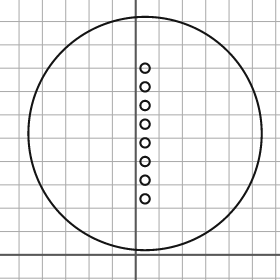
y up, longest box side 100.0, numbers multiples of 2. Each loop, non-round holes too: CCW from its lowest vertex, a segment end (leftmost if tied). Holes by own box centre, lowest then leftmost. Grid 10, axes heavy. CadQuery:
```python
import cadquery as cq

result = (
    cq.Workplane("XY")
    .moveTo(4.0, 52.0)
    .circle(50.0)
    .moveTo(4.0, 24.0)
    .circle(2.0)
    .moveTo(4.0, 32.0)
    .circle(2.0)
    .moveTo(4.0, 40.0)
    .circle(2.0)
    .moveTo(4.0, 48.0)
    .circle(2.0)
    .moveTo(4.0, 56.0)
    .circle(2.0)
    .moveTo(4.0, 64.0)
    .circle(2.0)
    .moveTo(4.0, 72.0)
    .circle(2.0)
    .moveTo(4.0, 80.0)
    .circle(2.0)
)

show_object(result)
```